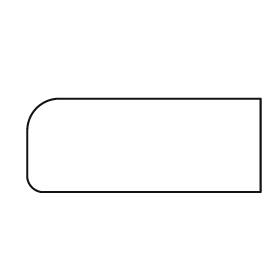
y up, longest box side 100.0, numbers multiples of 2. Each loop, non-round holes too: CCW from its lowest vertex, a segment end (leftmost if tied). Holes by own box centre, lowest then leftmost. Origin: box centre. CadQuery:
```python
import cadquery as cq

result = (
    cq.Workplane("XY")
    .moveTo(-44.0, -20.0)
    .lineTo(50.0, -20.0)
    .lineTo(50.0, 20.0)
    .lineTo(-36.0, 20.0)
    .threePointArc((-46.0, 16.0), (-50.0, 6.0))
    .lineTo(-50.0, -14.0)
    .threePointArc((-48.0, -18.0), (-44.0, -20.0))
    .close()
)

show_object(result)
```